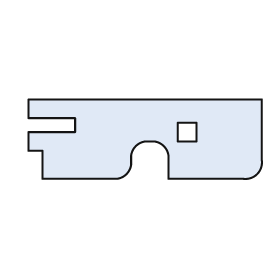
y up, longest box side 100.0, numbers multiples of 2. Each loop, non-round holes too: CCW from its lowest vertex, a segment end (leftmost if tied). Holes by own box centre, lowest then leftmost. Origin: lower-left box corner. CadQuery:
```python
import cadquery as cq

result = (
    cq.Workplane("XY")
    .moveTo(6.0, 0.0)
    .lineTo(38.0, 0.0)
    .threePointArc((42.0, 2.0), (44.0, 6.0))
    .lineTo(44.0, 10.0)
    .threePointArc((46.0, 14.0), (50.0, 16.0))
    .lineTo(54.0, 16.0)
    .threePointArc((58.0, 14.0), (60.0, 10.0))
    .lineTo(60.0, 0.0)
    .lineTo(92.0, 0.0)
    .threePointArc((98.0, 2.0), (100.0, 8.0))
    .lineTo(100.0, 34.0)
    .lineTo(0.0, 34.0)
    .lineTo(0.0, 26.0)
    .lineTo(20.0, 26.0)
    .lineTo(20.0, 20.0)
    .lineTo(0.0, 20.0)
    .lineTo(0.0, 12.0)
    .lineTo(6.0, 12.0)
    .close()
    .moveTo(64.0, 16.0)
    .lineTo(72.0, 16.0)
    .lineTo(72.0, 24.0)
    .lineTo(64.0, 24.0)
    .close()
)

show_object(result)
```